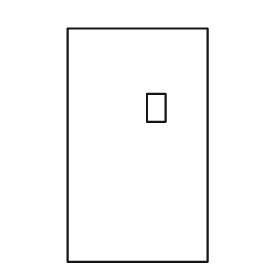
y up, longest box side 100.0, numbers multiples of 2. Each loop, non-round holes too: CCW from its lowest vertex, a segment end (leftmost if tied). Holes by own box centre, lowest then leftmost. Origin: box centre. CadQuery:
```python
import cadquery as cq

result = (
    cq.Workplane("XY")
    .moveTo(-30.0, -50.0)
    .lineTo(30.0, -50.0)
    .lineTo(30.0, 50.0)
    .lineTo(-30.0, 50.0)
    .close()
    .moveTo(4.0, 10.0)
    .lineTo(12.0, 10.0)
    .lineTo(12.0, 22.0)
    .lineTo(4.0, 22.0)
    .close()
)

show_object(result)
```